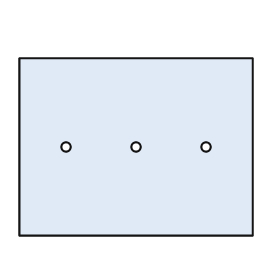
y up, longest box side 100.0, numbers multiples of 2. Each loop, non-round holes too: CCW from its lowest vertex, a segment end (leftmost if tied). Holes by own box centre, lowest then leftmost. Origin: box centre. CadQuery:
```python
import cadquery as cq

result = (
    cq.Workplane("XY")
    .moveTo(-50.0, -38.0)
    .lineTo(50.0, -38.0)
    .lineTo(50.0, 38.0)
    .lineTo(-50.0, 38.0)
    .close()
    .moveTo(-30.0, 0.0)
    .circle(2.0)
    .moveTo(0.0, 0.0)
    .circle(2.0)
    .moveTo(30.0, 0.0)
    .circle(2.0)
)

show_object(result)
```